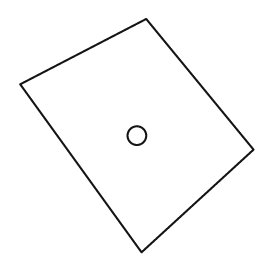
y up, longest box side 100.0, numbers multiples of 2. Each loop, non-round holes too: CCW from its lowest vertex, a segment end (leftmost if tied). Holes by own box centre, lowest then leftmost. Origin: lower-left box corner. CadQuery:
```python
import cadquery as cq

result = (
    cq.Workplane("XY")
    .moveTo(52.0, 0.0)
    .lineTo(100.0, 44.0)
    .lineTo(54.0, 100.0)
    .lineTo(0.0, 72.0)
    .close()
    .moveTo(50.0, 50.0)
    .circle(4.0)
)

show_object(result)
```